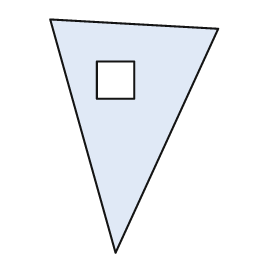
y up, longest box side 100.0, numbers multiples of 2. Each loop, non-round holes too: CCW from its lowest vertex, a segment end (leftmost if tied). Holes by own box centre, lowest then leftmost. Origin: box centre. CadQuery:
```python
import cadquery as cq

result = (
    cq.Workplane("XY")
    .moveTo(-8.0, -50.0)
    .lineTo(36.0, 46.0)
    .lineTo(-36.0, 50.0)
    .close()
    .moveTo(-16.0, 16.0)
    .lineTo(0.0, 16.0)
    .lineTo(0.0, 32.0)
    .lineTo(-16.0, 32.0)
    .close()
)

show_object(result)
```